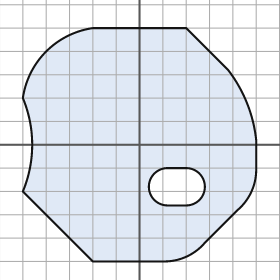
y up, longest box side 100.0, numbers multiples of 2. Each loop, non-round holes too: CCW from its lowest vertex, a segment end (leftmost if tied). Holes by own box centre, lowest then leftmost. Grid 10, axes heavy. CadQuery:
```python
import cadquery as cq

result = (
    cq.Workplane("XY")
    .moveTo(-20.0, -50.0)
    .lineTo(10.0, -50.0)
    .threePointArc((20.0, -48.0), (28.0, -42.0))
    .lineTo(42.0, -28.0)
    .threePointArc((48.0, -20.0), (50.0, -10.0))
    .lineTo(50.0, 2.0)
    .threePointArc((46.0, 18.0), (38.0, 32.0))
    .lineTo(20.0, 50.0)
    .lineTo(-20.0, 50.0)
    .threePointArc((-40.0, 40.0), (-50.0, 20.0))
    .threePointArc((-46.0, 0.0), (-50.0, -20.0))
    .close()
    .moveTo(12.0, -26.0)
    .lineTo(20.0, -26.0)
    .threePointArc((28.0, -18.0), (20.0, -10.0))
    .lineTo(12.0, -10.0)
    .threePointArc((4.0, -18.0), (12.0, -26.0))
    .close()
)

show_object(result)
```